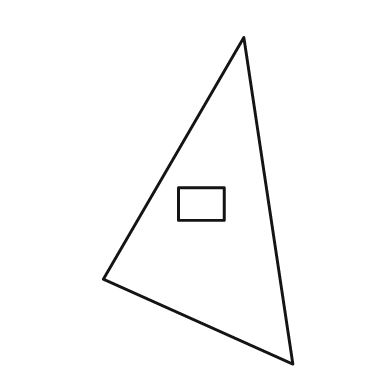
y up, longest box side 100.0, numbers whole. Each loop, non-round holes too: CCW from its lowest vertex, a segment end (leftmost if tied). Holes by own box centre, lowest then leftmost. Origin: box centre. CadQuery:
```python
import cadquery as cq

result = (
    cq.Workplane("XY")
    .moveTo(29.0, -50.0)
    .lineTo(14.0, 50.0)
    .lineTo(-29.0, -24.0)
    .close()
    .moveTo(-6.0, -6.0)
    .lineTo(8.0, -6.0)
    .lineTo(8.0, 4.0)
    .lineTo(-6.0, 4.0)
    .close()
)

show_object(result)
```